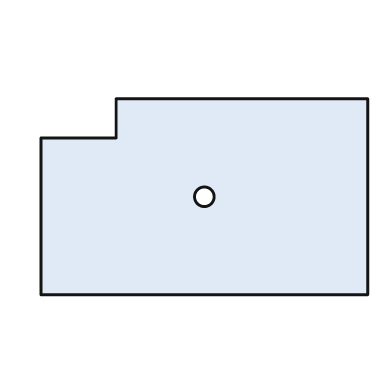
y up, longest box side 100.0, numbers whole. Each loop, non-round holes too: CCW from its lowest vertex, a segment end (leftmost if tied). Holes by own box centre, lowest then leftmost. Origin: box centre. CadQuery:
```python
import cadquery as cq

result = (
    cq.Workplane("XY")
    .moveTo(-50.0, -30.0)
    .lineTo(50.0, -30.0)
    .lineTo(50.0, 30.0)
    .lineTo(-27.0, 30.0)
    .lineTo(-27.0, 18.0)
    .lineTo(-50.0, 18.0)
    .close()
    .moveTo(0.0, 0.0)
    .circle(3.0)
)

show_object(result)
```